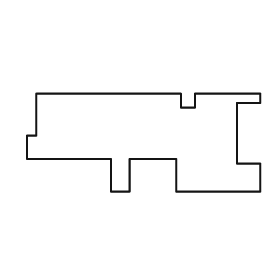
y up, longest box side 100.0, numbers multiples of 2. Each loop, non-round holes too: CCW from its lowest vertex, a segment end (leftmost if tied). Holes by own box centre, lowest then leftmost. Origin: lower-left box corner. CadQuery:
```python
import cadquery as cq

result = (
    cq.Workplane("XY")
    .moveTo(36.0, 0.0)
    .lineTo(44.0, 0.0)
    .lineTo(44.0, 14.0)
    .lineTo(64.0, 14.0)
    .lineTo(64.0, 0.0)
    .lineTo(100.0, 0.0)
    .lineTo(100.0, 12.0)
    .lineTo(90.0, 12.0)
    .lineTo(90.0, 38.0)
    .lineTo(100.0, 38.0)
    .lineTo(100.0, 42.0)
    .lineTo(72.0, 42.0)
    .lineTo(72.0, 36.0)
    .lineTo(66.0, 36.0)
    .lineTo(66.0, 42.0)
    .lineTo(4.0, 42.0)
    .lineTo(4.0, 24.0)
    .lineTo(0.0, 24.0)
    .lineTo(0.0, 14.0)
    .lineTo(36.0, 14.0)
    .close()
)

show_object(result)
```